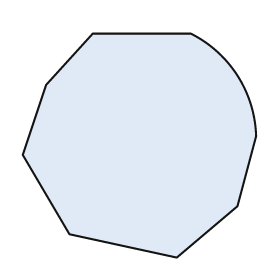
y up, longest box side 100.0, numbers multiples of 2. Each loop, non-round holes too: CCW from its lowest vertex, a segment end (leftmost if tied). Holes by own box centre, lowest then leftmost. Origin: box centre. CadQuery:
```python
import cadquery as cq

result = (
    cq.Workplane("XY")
    .moveTo(16.0, -48.0)
    .lineTo(42.0, -26.0)
    .lineTo(50.0, 4.0)
    .threePointArc((42.0, 30.0), (22.0, 48.0))
    .lineTo(-20.0, 48.0)
    .lineTo(-40.0, 26.0)
    .lineTo(-50.0, -4.0)
    .lineTo(-30.0, -38.0)
    .close()
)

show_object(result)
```